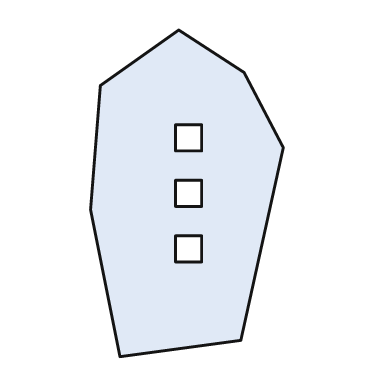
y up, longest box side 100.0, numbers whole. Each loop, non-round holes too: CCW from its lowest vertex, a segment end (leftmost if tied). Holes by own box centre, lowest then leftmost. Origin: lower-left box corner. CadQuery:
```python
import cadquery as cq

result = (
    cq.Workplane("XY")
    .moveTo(9.0, 0.0)
    .lineTo(46.0, 5.0)
    .lineTo(59.0, 64.0)
    .lineTo(47.0, 87.0)
    .lineTo(27.0, 100.0)
    .lineTo(3.0, 83.0)
    .lineTo(0.0, 45.0)
    .close()
    .moveTo(26.0, 29.0)
    .lineTo(34.0, 29.0)
    .lineTo(34.0, 37.0)
    .lineTo(26.0, 37.0)
    .close()
    .moveTo(26.0, 46.0)
    .lineTo(34.0, 46.0)
    .lineTo(34.0, 54.0)
    .lineTo(26.0, 54.0)
    .close()
    .moveTo(26.0, 63.0)
    .lineTo(34.0, 63.0)
    .lineTo(34.0, 71.0)
    .lineTo(26.0, 71.0)
    .close()
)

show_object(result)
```